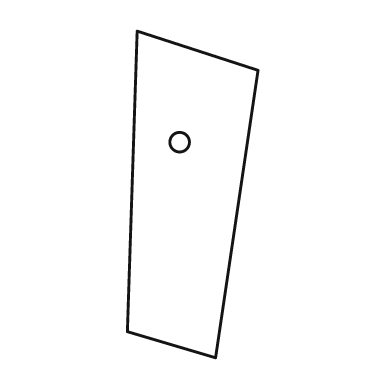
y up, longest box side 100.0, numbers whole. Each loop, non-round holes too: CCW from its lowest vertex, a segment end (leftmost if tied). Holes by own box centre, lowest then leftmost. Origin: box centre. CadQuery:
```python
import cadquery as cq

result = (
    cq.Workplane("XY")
    .moveTo(7.0, -50.0)
    .lineTo(20.0, 38.0)
    .lineTo(-17.0, 50.0)
    .lineTo(-20.0, -42.0)
    .close()
    .moveTo(-4.0, 16.0)
    .circle(3.0)
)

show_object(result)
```